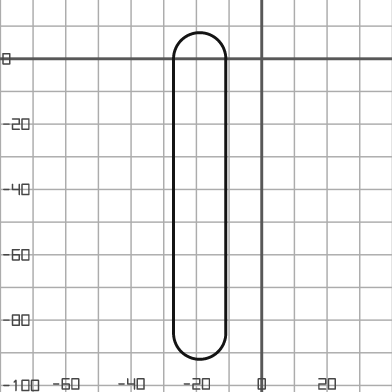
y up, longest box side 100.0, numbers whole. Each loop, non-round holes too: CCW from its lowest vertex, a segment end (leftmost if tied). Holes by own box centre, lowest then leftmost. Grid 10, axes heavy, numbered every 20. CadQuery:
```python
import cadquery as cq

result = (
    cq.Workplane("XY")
    .moveTo(-27.0, -84.0)
    .threePointArc((-19.0, -92.0), (-11.0, -84.0))
    .lineTo(-11.0, 0.0)
    .threePointArc((-19.0, 8.0), (-27.0, 0.0))
    .close()
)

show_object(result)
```